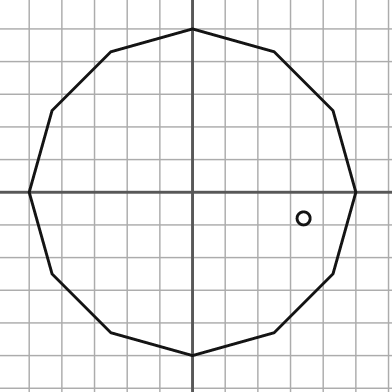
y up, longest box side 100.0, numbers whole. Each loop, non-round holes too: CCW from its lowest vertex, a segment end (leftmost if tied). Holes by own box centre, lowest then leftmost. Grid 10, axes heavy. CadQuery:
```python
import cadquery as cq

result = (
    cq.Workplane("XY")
    .moveTo(0.0, -50.0)
    .lineTo(25.0, -43.0)
    .lineTo(43.0, -25.0)
    .lineTo(50.0, 0.0)
    .lineTo(43.0, 25.0)
    .lineTo(25.0, 43.0)
    .lineTo(0.0, 50.0)
    .lineTo(-25.0, 43.0)
    .lineTo(-43.0, 25.0)
    .lineTo(-50.0, 0.0)
    .lineTo(-43.0, -25.0)
    .lineTo(-25.0, -43.0)
    .close()
    .moveTo(34.0, -8.0)
    .circle(2.0)
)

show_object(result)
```